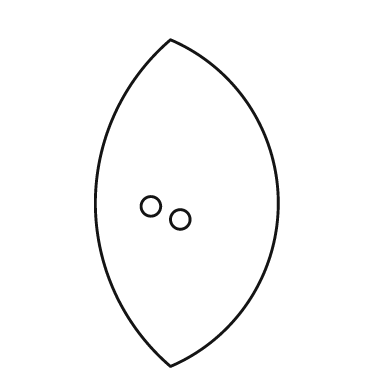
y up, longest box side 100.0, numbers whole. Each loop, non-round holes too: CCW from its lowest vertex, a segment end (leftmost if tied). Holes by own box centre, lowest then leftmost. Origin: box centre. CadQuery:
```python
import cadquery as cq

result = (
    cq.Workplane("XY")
    .moveTo(-5.0, -50.0)
    .threePointArc((28.0, 0.0), (-5.0, 50.0))
    .threePointArc((-28.0, 0.0), (-5.0, -50.0))
    .close()
    .moveTo(-2.0, -5.0)
    .circle(3.0)
    .moveTo(-11.0, -1.0)
    .circle(3.0)
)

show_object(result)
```